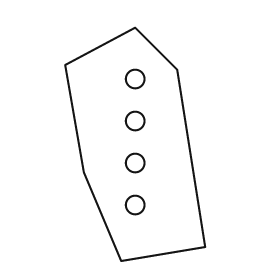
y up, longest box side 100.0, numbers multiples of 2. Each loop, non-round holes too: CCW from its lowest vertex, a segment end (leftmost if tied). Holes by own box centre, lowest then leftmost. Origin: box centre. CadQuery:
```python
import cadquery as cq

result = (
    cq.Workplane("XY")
    .moveTo(-6.0, -50.0)
    .lineTo(30.0, -44.0)
    .lineTo(18.0, 32.0)
    .lineTo(0.0, 50.0)
    .lineTo(-30.0, 34.0)
    .lineTo(-22.0, -12.0)
    .close()
    .moveTo(0.0, -26.0)
    .circle(4.0)
    .moveTo(0.0, -8.0)
    .circle(4.0)
    .moveTo(0.0, 10.0)
    .circle(4.0)
    .moveTo(0.0, 28.0)
    .circle(4.0)
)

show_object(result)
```